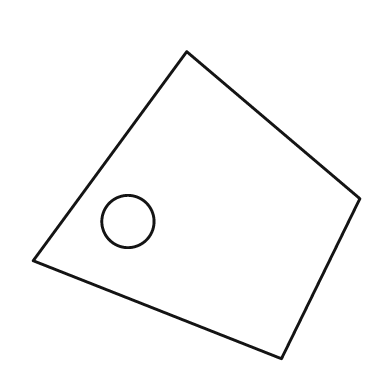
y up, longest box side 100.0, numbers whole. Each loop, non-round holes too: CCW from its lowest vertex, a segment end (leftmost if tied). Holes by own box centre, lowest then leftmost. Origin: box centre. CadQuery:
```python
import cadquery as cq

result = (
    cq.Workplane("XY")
    .moveTo(26.0, -47.0)
    .lineTo(50.0, 2.0)
    .lineTo(-3.0, 47.0)
    .lineTo(-50.0, -17.0)
    .close()
    .moveTo(-21.0, -5.0)
    .circle(8.0)
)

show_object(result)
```